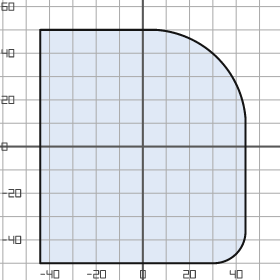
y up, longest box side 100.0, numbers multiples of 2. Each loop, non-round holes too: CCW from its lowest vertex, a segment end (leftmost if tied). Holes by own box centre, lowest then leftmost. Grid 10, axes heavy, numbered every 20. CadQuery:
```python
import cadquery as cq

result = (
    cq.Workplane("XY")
    .moveTo(-44.0, -50.0)
    .lineTo(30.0, -50.0)
    .threePointArc((40.0, -46.0), (44.0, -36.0))
    .lineTo(44.0, 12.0)
    .threePointArc((32.0, 38.0), (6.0, 50.0))
    .lineTo(-44.0, 50.0)
    .close()
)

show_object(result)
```